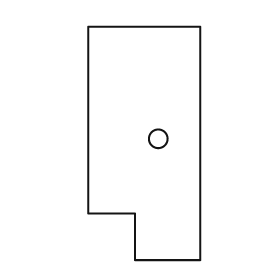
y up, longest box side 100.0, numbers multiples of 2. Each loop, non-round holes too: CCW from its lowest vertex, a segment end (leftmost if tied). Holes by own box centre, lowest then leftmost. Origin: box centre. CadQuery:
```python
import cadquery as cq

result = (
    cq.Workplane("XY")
    .moveTo(-4.0, -50.0)
    .lineTo(24.0, -50.0)
    .lineTo(24.0, 50.0)
    .lineTo(-24.0, 50.0)
    .lineTo(-24.0, -30.0)
    .lineTo(-4.0, -30.0)
    .close()
    .moveTo(6.0, 2.0)
    .circle(4.0)
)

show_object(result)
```